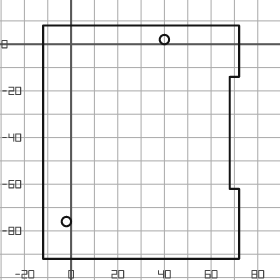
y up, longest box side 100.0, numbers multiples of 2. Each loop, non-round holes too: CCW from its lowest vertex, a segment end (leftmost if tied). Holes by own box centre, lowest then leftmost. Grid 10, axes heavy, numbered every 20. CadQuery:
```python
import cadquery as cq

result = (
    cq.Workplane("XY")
    .moveTo(-12.0, -92.0)
    .lineTo(72.0, -92.0)
    .lineTo(72.0, -62.0)
    .lineTo(68.0, -62.0)
    .lineTo(68.0, -14.0)
    .lineTo(72.0, -14.0)
    .lineTo(72.0, 8.0)
    .lineTo(-12.0, 8.0)
    .close()
    .moveTo(-2.0, -76.0)
    .circle(2.0)
    .moveTo(40.0, 2.0)
    .circle(2.0)
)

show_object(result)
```